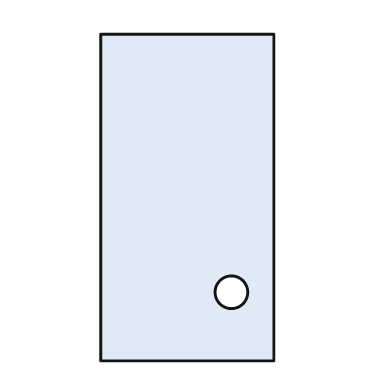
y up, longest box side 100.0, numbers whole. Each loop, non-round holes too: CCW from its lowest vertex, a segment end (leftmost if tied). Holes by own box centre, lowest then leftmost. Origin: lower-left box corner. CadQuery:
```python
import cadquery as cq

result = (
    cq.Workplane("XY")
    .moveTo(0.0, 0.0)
    .lineTo(53.0, 0.0)
    .lineTo(53.0, 100.0)
    .lineTo(0.0, 100.0)
    .close()
    .moveTo(40.0, 21.0)
    .circle(5.0)
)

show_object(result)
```